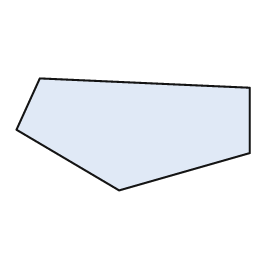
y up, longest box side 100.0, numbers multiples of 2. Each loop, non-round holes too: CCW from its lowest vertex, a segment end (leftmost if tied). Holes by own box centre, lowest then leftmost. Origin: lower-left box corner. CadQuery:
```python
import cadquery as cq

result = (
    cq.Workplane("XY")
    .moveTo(44.0, 0.0)
    .lineTo(100.0, 16.0)
    .lineTo(100.0, 44.0)
    .lineTo(10.0, 48.0)
    .lineTo(0.0, 26.0)
    .close()
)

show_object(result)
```